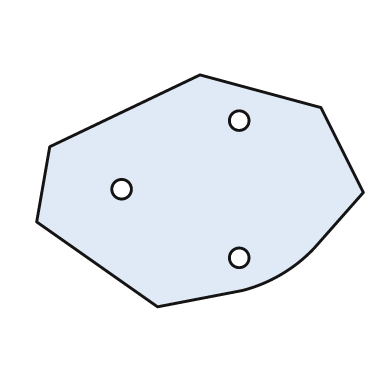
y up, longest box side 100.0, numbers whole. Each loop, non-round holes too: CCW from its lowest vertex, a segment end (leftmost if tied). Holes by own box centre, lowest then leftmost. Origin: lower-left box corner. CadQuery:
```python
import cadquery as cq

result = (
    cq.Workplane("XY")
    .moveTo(37.0, 0.0)
    .lineTo(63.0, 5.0)
    .threePointArc((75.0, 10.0), (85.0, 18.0))
    .lineTo(100.0, 35.0)
    .lineTo(87.0, 61.0)
    .lineTo(50.0, 71.0)
    .lineTo(4.0, 49.0)
    .lineTo(0.0, 26.0)
    .close()
    .moveTo(62.0, 15.0)
    .circle(3.0)
    .moveTo(26.0, 36.0)
    .circle(3.0)
    .moveTo(62.0, 57.0)
    .circle(3.0)
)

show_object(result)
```